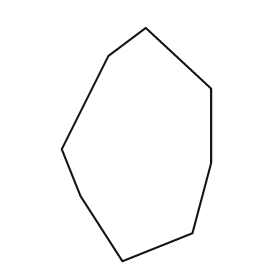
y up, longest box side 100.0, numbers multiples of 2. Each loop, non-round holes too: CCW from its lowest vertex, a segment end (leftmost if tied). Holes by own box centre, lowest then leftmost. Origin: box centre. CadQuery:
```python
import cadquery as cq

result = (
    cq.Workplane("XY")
    .moveTo(-6.0, -50.0)
    .lineTo(24.0, -38.0)
    .lineTo(32.0, -8.0)
    .lineTo(32.0, 24.0)
    .lineTo(4.0, 50.0)
    .lineTo(-12.0, 38.0)
    .lineTo(-32.0, -2.0)
    .lineTo(-24.0, -22.0)
    .close()
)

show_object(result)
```